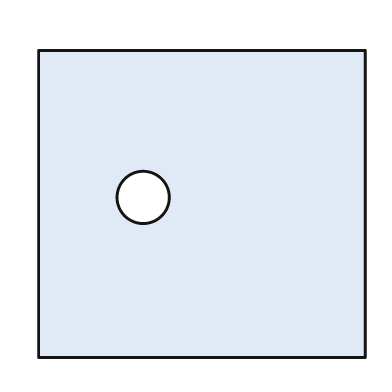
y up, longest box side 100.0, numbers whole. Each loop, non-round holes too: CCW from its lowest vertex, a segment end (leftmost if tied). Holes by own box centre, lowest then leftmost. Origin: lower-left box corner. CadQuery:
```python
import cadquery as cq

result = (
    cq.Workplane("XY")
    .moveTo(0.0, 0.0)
    .lineTo(100.0, 0.0)
    .lineTo(100.0, 94.0)
    .lineTo(0.0, 94.0)
    .close()
    .moveTo(32.0, 49.0)
    .circle(8.0)
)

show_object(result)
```